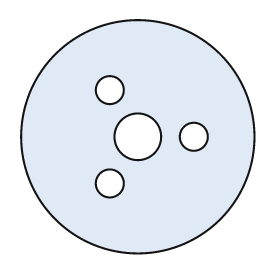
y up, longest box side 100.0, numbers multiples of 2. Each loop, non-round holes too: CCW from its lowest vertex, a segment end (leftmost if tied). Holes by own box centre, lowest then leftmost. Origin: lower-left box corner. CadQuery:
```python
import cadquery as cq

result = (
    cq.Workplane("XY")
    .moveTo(50.0, 50.0)
    .circle(50.0)
    .moveTo(38.0, 30.0)
    .circle(6.0)
    .moveTo(50.0, 50.0)
    .circle(10.0)
    .moveTo(74.0, 50.0)
    .circle(6.0)
    .moveTo(38.0, 70.0)
    .circle(6.0)
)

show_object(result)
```